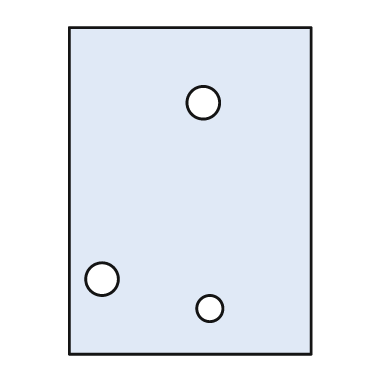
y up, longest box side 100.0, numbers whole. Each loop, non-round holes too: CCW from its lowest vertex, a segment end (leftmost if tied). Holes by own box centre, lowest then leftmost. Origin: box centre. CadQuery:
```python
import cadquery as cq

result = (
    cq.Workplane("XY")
    .moveTo(-37.0, -50.0)
    .lineTo(37.0, -50.0)
    .lineTo(37.0, 50.0)
    .lineTo(-37.0, 50.0)
    .close()
    .moveTo(6.0, -36.0)
    .circle(4.0)
    .moveTo(-27.0, -27.0)
    .circle(5.0)
    .moveTo(4.0, 27.0)
    .circle(5.0)
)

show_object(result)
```